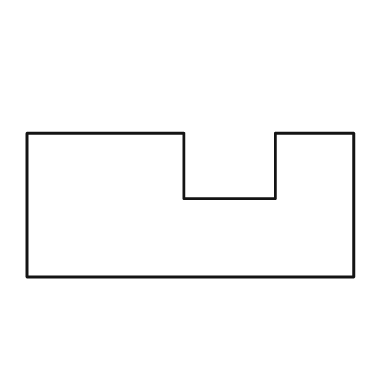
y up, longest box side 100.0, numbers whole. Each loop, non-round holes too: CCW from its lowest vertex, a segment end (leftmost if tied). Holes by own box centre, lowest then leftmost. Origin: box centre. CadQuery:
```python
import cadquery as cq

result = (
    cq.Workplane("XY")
    .moveTo(-50.0, -22.0)
    .lineTo(50.0, -22.0)
    .lineTo(50.0, 22.0)
    .lineTo(26.0, 22.0)
    .lineTo(26.0, 2.0)
    .lineTo(-2.0, 2.0)
    .lineTo(-2.0, 22.0)
    .lineTo(-50.0, 22.0)
    .close()
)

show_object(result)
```